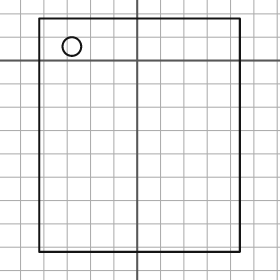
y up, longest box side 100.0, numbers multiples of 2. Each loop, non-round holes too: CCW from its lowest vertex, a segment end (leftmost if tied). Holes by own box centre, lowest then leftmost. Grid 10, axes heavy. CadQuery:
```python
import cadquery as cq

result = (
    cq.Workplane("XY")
    .moveTo(-42.0, -82.0)
    .lineTo(44.0, -82.0)
    .lineTo(44.0, 18.0)
    .lineTo(-42.0, 18.0)
    .close()
    .moveTo(-28.0, 6.0)
    .circle(4.0)
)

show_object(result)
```